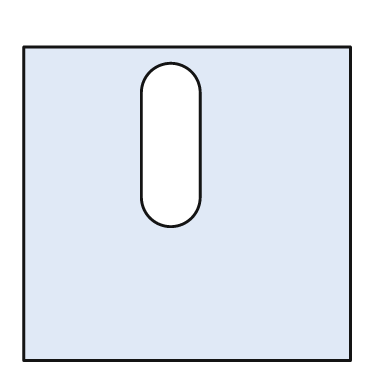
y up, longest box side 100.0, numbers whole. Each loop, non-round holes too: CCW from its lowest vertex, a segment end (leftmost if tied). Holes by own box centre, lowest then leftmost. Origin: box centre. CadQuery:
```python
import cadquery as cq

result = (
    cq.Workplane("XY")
    .moveTo(-50.0, -48.0)
    .lineTo(50.0, -48.0)
    .lineTo(50.0, 48.0)
    .lineTo(-50.0, 48.0)
    .close()
    .moveTo(-14.0, 2.0)
    .threePointArc((-5.0, -7.0), (4.0, 2.0))
    .lineTo(4.0, 34.0)
    .threePointArc((-5.0, 43.0), (-14.0, 34.0))
    .close()
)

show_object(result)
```